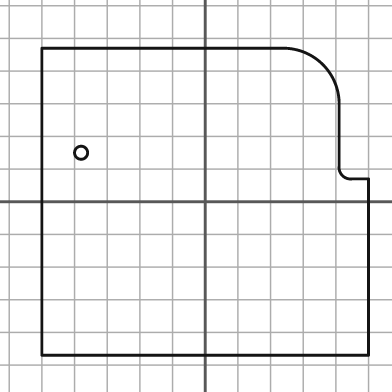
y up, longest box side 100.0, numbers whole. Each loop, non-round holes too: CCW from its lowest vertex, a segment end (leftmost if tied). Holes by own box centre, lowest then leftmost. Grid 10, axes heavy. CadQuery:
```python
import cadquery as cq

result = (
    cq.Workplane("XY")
    .moveTo(-50.0, -47.0)
    .lineTo(50.0, -47.0)
    .lineTo(50.0, 7.0)
    .lineTo(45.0, 7.0)
    .threePointArc((42.0, 8.0), (41.0, 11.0))
    .lineTo(41.0, 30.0)
    .threePointArc((36.0, 42.0), (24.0, 47.0))
    .lineTo(-50.0, 47.0)
    .close()
    .moveTo(-38.0, 15.0)
    .circle(2.0)
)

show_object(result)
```